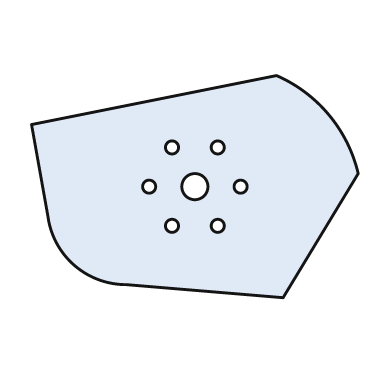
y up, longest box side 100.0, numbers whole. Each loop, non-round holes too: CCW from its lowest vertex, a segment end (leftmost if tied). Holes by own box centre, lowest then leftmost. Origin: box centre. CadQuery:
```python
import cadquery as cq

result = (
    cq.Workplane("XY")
    .moveTo(27.0, -34.0)
    .lineTo(50.0, 4.0)
    .threePointArc((41.0, 22.0), (25.0, 34.0))
    .lineTo(-50.0, 19.0)
    .lineTo(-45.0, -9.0)
    .threePointArc((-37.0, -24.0), (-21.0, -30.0))
    .close()
    .moveTo(-7.0, -12.0)
    .circle(2.0)
    .moveTo(7.0, -12.0)
    .circle(2.0)
    .moveTo(-14.0, 0.0)
    .circle(2.0)
    .moveTo(0.0, 0.0)
    .circle(4.0)
    .moveTo(14.0, 0.0)
    .circle(2.0)
    .moveTo(-7.0, 12.0)
    .circle(2.0)
    .moveTo(7.0, 12.0)
    .circle(2.0)
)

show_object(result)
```